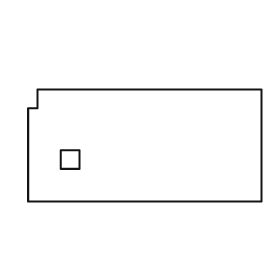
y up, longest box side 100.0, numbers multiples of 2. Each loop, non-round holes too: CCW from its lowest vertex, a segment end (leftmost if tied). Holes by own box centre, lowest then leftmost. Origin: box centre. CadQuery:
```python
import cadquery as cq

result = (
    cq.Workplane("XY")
    .moveTo(-50.0, -24.0)
    .lineTo(50.0, -24.0)
    .lineTo(50.0, 24.0)
    .lineTo(-46.0, 24.0)
    .lineTo(-46.0, 16.0)
    .lineTo(-50.0, 16.0)
    .close()
    .moveTo(-36.0, -10.0)
    .lineTo(-28.0, -10.0)
    .lineTo(-28.0, -2.0)
    .lineTo(-36.0, -2.0)
    .close()
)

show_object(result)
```